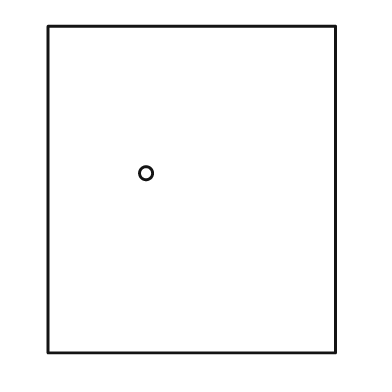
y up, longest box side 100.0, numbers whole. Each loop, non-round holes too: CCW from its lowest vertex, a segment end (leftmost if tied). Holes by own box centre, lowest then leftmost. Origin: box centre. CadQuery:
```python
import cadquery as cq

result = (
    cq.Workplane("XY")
    .moveTo(-44.0, -50.0)
    .lineTo(44.0, -50.0)
    .lineTo(44.0, 50.0)
    .lineTo(-44.0, 50.0)
    .close()
    .moveTo(-14.0, 5.0)
    .circle(2.0)
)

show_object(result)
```